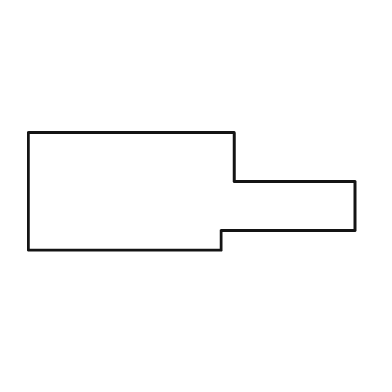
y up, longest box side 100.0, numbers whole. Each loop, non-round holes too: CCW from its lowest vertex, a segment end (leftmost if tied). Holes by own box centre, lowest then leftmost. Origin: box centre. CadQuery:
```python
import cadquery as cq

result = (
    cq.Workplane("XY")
    .moveTo(-50.0, -18.0)
    .lineTo(9.0, -18.0)
    .lineTo(9.0, -12.0)
    .lineTo(50.0, -12.0)
    .lineTo(50.0, 3.0)
    .lineTo(13.0, 3.0)
    .lineTo(13.0, 18.0)
    .lineTo(-50.0, 18.0)
    .close()
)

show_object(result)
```